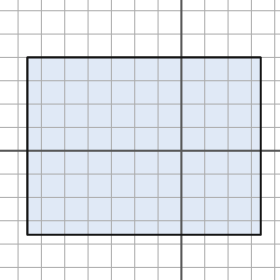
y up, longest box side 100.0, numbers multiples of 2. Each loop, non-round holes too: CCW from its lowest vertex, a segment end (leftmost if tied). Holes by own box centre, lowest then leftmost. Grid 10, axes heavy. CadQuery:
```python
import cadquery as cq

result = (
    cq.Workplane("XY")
    .moveTo(-66.0, -36.0)
    .lineTo(34.0, -36.0)
    .lineTo(34.0, 40.0)
    .lineTo(-66.0, 40.0)
    .close()
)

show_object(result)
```